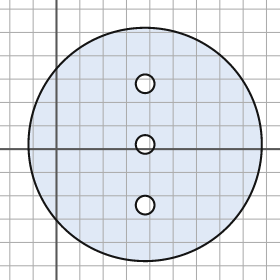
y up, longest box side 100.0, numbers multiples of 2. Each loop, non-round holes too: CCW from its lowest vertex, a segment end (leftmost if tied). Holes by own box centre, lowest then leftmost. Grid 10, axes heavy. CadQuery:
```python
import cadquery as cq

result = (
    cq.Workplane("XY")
    .moveTo(38.0, 2.0)
    .circle(50.0)
    .moveTo(38.0, -24.0)
    .circle(4.0)
    .moveTo(38.0, 2.0)
    .circle(4.0)
    .moveTo(38.0, 28.0)
    .circle(4.0)
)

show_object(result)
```